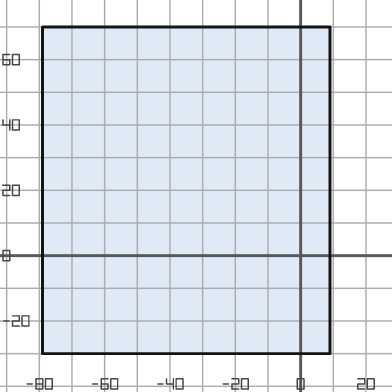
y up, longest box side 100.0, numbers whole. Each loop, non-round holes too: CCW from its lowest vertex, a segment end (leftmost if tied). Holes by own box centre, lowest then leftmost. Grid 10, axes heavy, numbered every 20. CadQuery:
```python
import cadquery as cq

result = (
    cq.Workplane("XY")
    .moveTo(-79.0, -30.0)
    .lineTo(9.0, -30.0)
    .lineTo(9.0, 70.0)
    .lineTo(-79.0, 70.0)
    .close()
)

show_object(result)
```